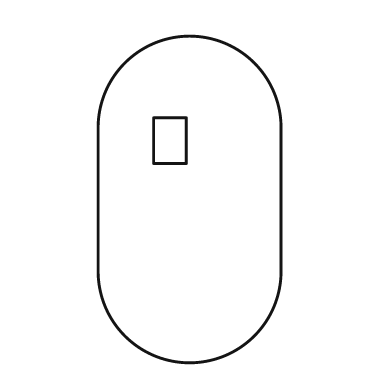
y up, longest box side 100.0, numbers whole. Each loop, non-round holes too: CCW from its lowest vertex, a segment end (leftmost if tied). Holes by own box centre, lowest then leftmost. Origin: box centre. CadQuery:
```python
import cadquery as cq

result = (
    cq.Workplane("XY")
    .moveTo(-28.0, -22.0)
    .threePointArc((0.0, -50.0), (28.0, -22.0))
    .lineTo(28.0, 22.0)
    .threePointArc((0.0, 50.0), (-28.0, 22.0))
    .close()
    .moveTo(-11.0, 11.0)
    .lineTo(-1.0, 11.0)
    .lineTo(-1.0, 25.0)
    .lineTo(-11.0, 25.0)
    .close()
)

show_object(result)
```